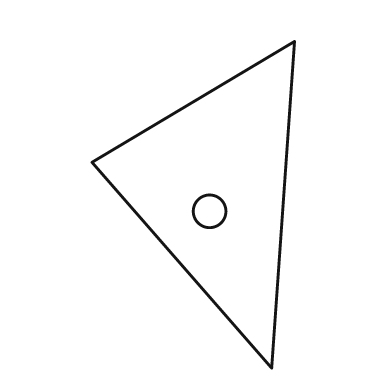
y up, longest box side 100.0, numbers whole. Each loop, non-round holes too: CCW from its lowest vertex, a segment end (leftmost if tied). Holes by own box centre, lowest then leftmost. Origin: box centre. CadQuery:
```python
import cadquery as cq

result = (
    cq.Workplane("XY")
    .moveTo(24.0, -50.0)
    .lineTo(31.0, 50.0)
    .lineTo(-31.0, 13.0)
    .close()
    .moveTo(5.0, -2.0)
    .circle(5.0)
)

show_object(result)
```